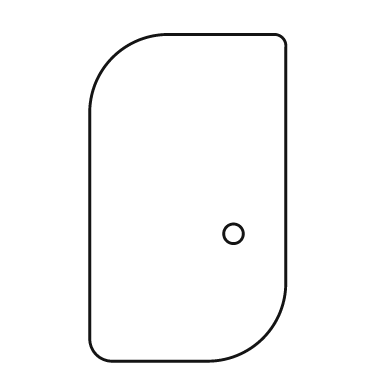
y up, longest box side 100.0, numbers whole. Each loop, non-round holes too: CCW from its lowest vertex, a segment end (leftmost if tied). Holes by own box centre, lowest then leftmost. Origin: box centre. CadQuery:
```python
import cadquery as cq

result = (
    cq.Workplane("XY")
    .moveTo(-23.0, -50.0)
    .lineTo(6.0, -50.0)
    .threePointArc((23.0, -43.0), (30.0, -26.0))
    .lineTo(30.0, 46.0)
    .threePointArc((29.0, 49.0), (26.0, 50.0))
    .lineTo(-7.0, 50.0)
    .threePointArc((-23.0, 43.0), (-30.0, 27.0))
    .lineTo(-30.0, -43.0)
    .threePointArc((-28.0, -48.0), (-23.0, -50.0))
    .close()
    .moveTo(14.0, -11.0)
    .circle(3.0)
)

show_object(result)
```